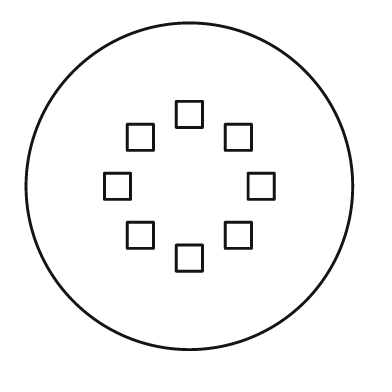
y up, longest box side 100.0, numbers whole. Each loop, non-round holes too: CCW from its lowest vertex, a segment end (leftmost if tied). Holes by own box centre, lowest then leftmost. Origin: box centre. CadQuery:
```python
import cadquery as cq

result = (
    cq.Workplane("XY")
    .moveTo(0.0, 0.0)
    .circle(50.0)
    .moveTo(-4.0, -26.0)
    .lineTo(4.0, -26.0)
    .lineTo(4.0, -18.0)
    .lineTo(-4.0, -18.0)
    .close()
    .moveTo(-19.0, -19.0)
    .lineTo(-11.0, -19.0)
    .lineTo(-11.0, -11.0)
    .lineTo(-19.0, -11.0)
    .close()
    .moveTo(11.0, -19.0)
    .lineTo(19.0, -19.0)
    .lineTo(19.0, -11.0)
    .lineTo(11.0, -11.0)
    .close()
    .moveTo(-26.0, -4.0)
    .lineTo(-18.0, -4.0)
    .lineTo(-18.0, 4.0)
    .lineTo(-26.0, 4.0)
    .close()
    .moveTo(18.0, -4.0)
    .lineTo(26.0, -4.0)
    .lineTo(26.0, 4.0)
    .lineTo(18.0, 4.0)
    .close()
    .moveTo(-19.0, 11.0)
    .lineTo(-11.0, 11.0)
    .lineTo(-11.0, 19.0)
    .lineTo(-19.0, 19.0)
    .close()
    .moveTo(11.0, 11.0)
    .lineTo(19.0, 11.0)
    .lineTo(19.0, 19.0)
    .lineTo(11.0, 19.0)
    .close()
    .moveTo(-4.0, 18.0)
    .lineTo(4.0, 18.0)
    .lineTo(4.0, 26.0)
    .lineTo(-4.0, 26.0)
    .close()
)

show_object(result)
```